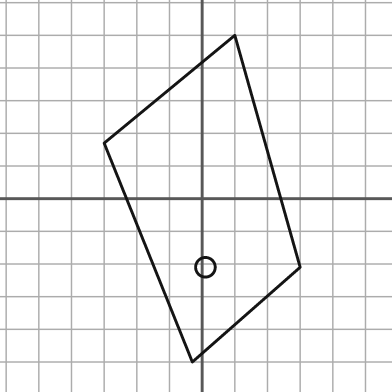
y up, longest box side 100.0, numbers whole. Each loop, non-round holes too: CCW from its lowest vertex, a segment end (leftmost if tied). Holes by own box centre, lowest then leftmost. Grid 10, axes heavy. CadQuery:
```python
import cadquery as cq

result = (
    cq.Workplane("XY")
    .moveTo(-3.0, -50.0)
    .lineTo(30.0, -21.0)
    .lineTo(10.0, 50.0)
    .lineTo(-30.0, 17.0)
    .close()
    .moveTo(1.0, -21.0)
    .circle(3.0)
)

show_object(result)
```